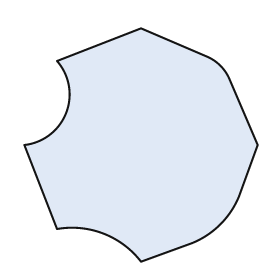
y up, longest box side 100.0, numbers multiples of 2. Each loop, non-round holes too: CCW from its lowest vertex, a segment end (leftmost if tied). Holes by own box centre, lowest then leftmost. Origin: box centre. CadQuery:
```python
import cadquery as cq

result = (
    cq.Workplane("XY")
    .moveTo(0.0, -50.0)
    .lineTo(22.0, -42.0)
    .threePointArc((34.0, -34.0), (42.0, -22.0))
    .lineTo(50.0, 0.0)
    .lineTo(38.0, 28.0)
    .threePointArc((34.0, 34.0), (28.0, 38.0))
    .lineTo(0.0, 50.0)
    .lineTo(-36.0, 36.0)
    .threePointArc((-32.0, 14.0), (-50.0, 0.0))
    .lineTo(-36.0, -36.0)
    .threePointArc((-16.0, -38.0), (0.0, -50.0))
    .close()
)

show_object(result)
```